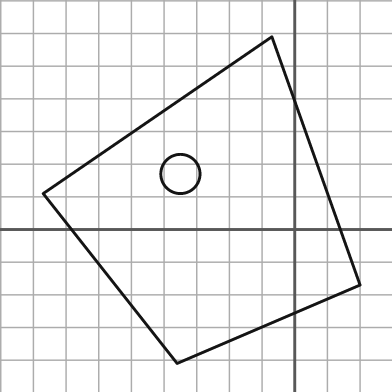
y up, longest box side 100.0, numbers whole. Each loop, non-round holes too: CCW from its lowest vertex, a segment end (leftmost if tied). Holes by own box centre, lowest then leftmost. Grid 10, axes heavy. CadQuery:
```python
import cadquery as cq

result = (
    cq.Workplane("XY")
    .moveTo(-36.0, -41.0)
    .lineTo(20.0, -17.0)
    .lineTo(-7.0, 59.0)
    .lineTo(-77.0, 11.0)
    .close()
    .moveTo(-35.0, 17.0)
    .circle(6.0)
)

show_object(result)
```